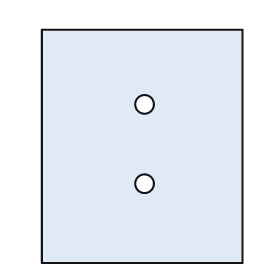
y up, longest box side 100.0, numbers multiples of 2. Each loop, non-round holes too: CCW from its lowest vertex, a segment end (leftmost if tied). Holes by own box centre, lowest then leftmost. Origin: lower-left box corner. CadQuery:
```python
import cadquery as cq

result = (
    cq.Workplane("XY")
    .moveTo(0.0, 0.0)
    .lineTo(86.0, 0.0)
    .lineTo(86.0, 100.0)
    .lineTo(0.0, 100.0)
    .close()
    .moveTo(44.0, 34.0)
    .circle(4.0)
    .moveTo(44.0, 68.0)
    .circle(4.0)
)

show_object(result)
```